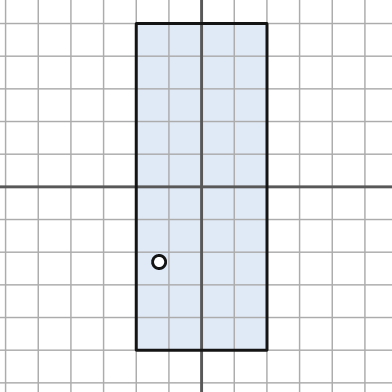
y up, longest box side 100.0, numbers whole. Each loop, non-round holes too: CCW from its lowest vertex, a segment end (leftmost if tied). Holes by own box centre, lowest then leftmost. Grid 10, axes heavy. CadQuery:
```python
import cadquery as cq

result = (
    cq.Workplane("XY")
    .moveTo(-20.0, -50.0)
    .lineTo(20.0, -50.0)
    .lineTo(20.0, 50.0)
    .lineTo(-20.0, 50.0)
    .close()
    .moveTo(-13.0, -23.0)
    .circle(2.0)
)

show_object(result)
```